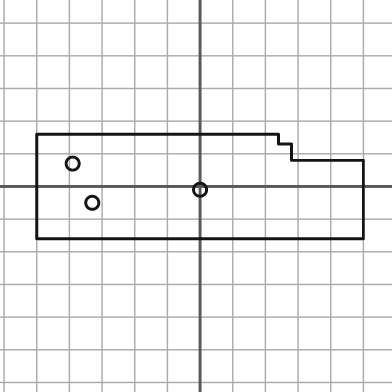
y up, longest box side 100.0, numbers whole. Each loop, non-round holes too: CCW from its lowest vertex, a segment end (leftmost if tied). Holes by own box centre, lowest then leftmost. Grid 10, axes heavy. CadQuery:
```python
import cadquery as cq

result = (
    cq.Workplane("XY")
    .moveTo(-50.0, -16.0)
    .lineTo(50.0, -16.0)
    .lineTo(50.0, 8.0)
    .lineTo(28.0, 8.0)
    .lineTo(28.0, 13.0)
    .lineTo(24.0, 13.0)
    .lineTo(24.0, 16.0)
    .lineTo(-50.0, 16.0)
    .close()
    .moveTo(-33.0, -5.0)
    .circle(2.0)
    .moveTo(0.0, -1.0)
    .circle(2.0)
    .moveTo(-39.0, 7.0)
    .circle(2.0)
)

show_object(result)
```